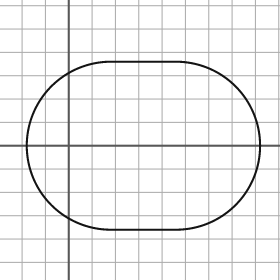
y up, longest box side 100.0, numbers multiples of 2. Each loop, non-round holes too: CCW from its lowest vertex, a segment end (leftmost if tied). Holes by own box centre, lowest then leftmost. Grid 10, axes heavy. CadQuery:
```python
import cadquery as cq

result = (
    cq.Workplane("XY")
    .moveTo(18.0, -36.0)
    .lineTo(46.0, -36.0)
    .threePointArc((82.0, 0.0), (46.0, 36.0))
    .lineTo(18.0, 36.0)
    .threePointArc((-18.0, 0.0), (18.0, -36.0))
    .close()
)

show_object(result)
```